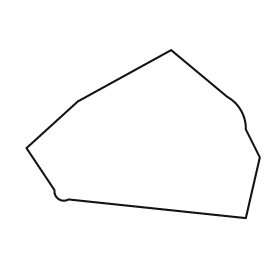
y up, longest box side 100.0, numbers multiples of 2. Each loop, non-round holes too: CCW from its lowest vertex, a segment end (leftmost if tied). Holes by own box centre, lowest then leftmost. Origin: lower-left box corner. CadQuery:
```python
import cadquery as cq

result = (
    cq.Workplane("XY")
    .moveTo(94.0, 0.0)
    .lineTo(100.0, 26.0)
    .lineTo(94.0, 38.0)
    .threePointArc((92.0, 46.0), (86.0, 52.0))
    .lineTo(62.0, 72.0)
    .lineTo(22.0, 50.0)
    .lineTo(0.0, 30.0)
    .lineTo(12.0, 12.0)
    .threePointArc((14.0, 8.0), (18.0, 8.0))
    .close()
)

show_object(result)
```